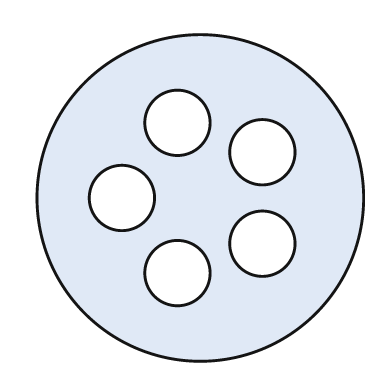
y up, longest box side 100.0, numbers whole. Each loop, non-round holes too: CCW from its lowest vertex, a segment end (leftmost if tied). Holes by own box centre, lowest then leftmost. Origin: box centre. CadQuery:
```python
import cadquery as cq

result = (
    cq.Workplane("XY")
    .moveTo(0.0, 0.0)
    .circle(50.0)
    .moveTo(-7.0, -23.0)
    .circle(10.0)
    .moveTo(19.0, -14.0)
    .circle(10.0)
    .moveTo(-24.0, 0.0)
    .circle(10.0)
    .moveTo(19.0, 14.0)
    .circle(10.0)
    .moveTo(-7.0, 23.0)
    .circle(10.0)
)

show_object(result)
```